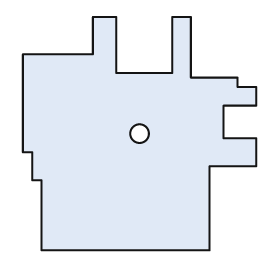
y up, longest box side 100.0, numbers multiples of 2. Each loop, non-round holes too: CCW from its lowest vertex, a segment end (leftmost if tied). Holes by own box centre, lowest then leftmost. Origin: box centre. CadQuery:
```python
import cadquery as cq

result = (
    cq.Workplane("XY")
    .moveTo(-42.0, -50.0)
    .lineTo(30.0, -50.0)
    .lineTo(30.0, -14.0)
    .lineTo(50.0, -14.0)
    .lineTo(50.0, -2.0)
    .lineTo(36.0, -2.0)
    .lineTo(36.0, 12.0)
    .lineTo(50.0, 12.0)
    .lineTo(50.0, 20.0)
    .lineTo(42.0, 20.0)
    .lineTo(42.0, 24.0)
    .lineTo(22.0, 24.0)
    .lineTo(22.0, 50.0)
    .lineTo(14.0, 50.0)
    .lineTo(14.0, 26.0)
    .lineTo(-10.0, 26.0)
    .lineTo(-10.0, 50.0)
    .lineTo(-20.0, 50.0)
    .lineTo(-20.0, 34.0)
    .lineTo(-50.0, 34.0)
    .lineTo(-50.0, -8.0)
    .lineTo(-46.0, -8.0)
    .lineTo(-46.0, -20.0)
    .lineTo(-42.0, -20.0)
    .close()
    .moveTo(0.0, 0.0)
    .circle(4.0)
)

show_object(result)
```